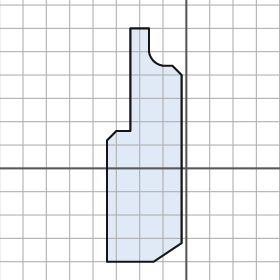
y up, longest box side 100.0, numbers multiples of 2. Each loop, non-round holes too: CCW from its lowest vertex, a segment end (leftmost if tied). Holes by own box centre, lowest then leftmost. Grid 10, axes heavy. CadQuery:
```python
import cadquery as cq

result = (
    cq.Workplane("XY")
    .moveTo(-34.0, -40.0)
    .lineTo(-14.0, -40.0)
    .lineTo(-2.0, -32.0)
    .lineTo(-2.0, 40.0)
    .lineTo(-6.0, 44.0)
    .lineTo(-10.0, 44.0)
    .threePointArc((-14.0, 46.0), (-16.0, 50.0))
    .lineTo(-16.0, 60.0)
    .lineTo(-24.0, 60.0)
    .lineTo(-24.0, 16.0)
    .lineTo(-30.0, 16.0)
    .lineTo(-34.0, 12.0)
    .close()
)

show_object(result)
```